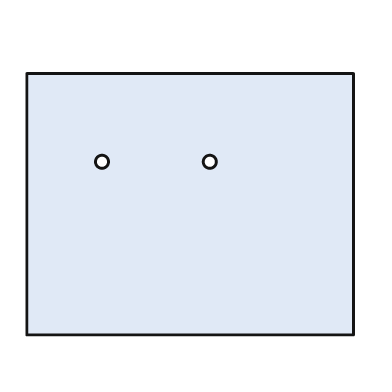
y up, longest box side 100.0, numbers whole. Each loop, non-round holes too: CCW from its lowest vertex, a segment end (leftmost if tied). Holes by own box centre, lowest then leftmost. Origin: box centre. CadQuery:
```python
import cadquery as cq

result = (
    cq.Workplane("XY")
    .moveTo(-50.0, -40.0)
    .lineTo(50.0, -40.0)
    .lineTo(50.0, 40.0)
    .lineTo(-50.0, 40.0)
    .close()
    .moveTo(-27.0, 13.0)
    .circle(2.0)
    .moveTo(6.0, 13.0)
    .circle(2.0)
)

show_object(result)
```